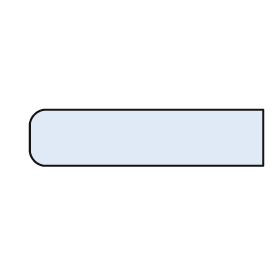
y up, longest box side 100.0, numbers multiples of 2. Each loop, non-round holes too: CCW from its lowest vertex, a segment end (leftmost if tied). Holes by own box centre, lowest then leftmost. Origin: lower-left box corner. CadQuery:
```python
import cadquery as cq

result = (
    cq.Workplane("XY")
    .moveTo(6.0, 0.0)
    .lineTo(100.0, 0.0)
    .lineTo(100.0, 24.0)
    .lineTo(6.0, 24.0)
    .threePointArc((2.0, 22.0), (0.0, 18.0))
    .lineTo(0.0, 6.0)
    .threePointArc((2.0, 2.0), (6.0, 0.0))
    .close()
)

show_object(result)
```